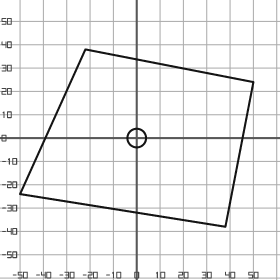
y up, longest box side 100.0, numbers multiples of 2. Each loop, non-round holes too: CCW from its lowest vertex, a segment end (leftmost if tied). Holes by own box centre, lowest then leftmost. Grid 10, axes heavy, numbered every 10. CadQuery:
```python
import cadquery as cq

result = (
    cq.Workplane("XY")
    .moveTo(38.0, -38.0)
    .lineTo(50.0, 24.0)
    .lineTo(-22.0, 38.0)
    .lineTo(-50.0, -24.0)
    .close()
    .moveTo(0.0, 0.0)
    .circle(4.0)
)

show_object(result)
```